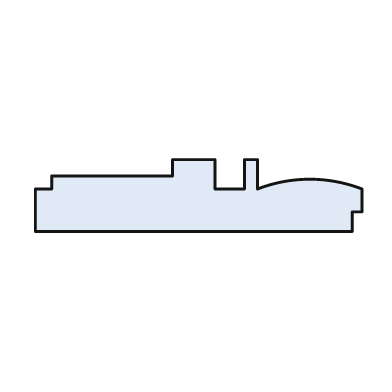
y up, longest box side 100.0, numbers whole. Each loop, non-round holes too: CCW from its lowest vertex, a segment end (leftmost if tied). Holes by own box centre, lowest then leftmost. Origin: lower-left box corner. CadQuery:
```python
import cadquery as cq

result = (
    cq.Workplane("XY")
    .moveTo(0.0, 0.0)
    .lineTo(97.0, 0.0)
    .lineTo(97.0, 6.0)
    .lineTo(100.0, 6.0)
    .lineTo(100.0, 13.0)
    .threePointArc((84.0, 16.0), (68.0, 13.0))
    .lineTo(68.0, 22.0)
    .lineTo(64.0, 22.0)
    .lineTo(64.0, 13.0)
    .lineTo(55.0, 13.0)
    .lineTo(55.0, 22.0)
    .lineTo(42.0, 22.0)
    .lineTo(42.0, 17.0)
    .lineTo(5.0, 17.0)
    .lineTo(5.0, 13.0)
    .lineTo(0.0, 13.0)
    .close()
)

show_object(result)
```